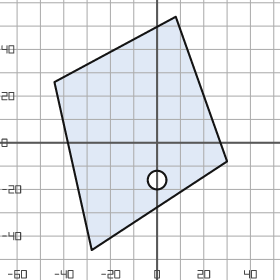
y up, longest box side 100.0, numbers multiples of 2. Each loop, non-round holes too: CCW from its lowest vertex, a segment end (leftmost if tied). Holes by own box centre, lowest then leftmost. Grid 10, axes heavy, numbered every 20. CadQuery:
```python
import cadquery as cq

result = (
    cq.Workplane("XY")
    .moveTo(-28.0, -46.0)
    .lineTo(30.0, -8.0)
    .lineTo(8.0, 54.0)
    .lineTo(-44.0, 26.0)
    .close()
    .moveTo(0.0, -16.0)
    .circle(4.0)
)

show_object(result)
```